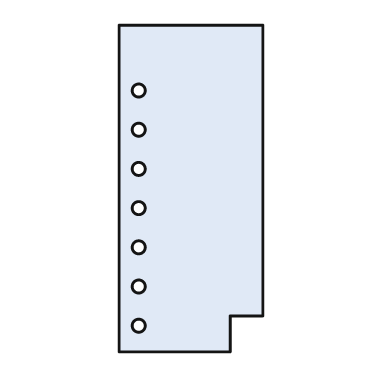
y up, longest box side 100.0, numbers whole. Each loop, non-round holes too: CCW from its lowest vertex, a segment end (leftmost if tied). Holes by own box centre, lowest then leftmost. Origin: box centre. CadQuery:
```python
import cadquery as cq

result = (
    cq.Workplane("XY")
    .moveTo(-22.0, -50.0)
    .lineTo(12.0, -50.0)
    .lineTo(12.0, -39.0)
    .lineTo(22.0, -39.0)
    .lineTo(22.0, 50.0)
    .lineTo(-22.0, 50.0)
    .close()
    .moveTo(-16.0, -42.0)
    .circle(2.0)
    .moveTo(-16.0, -30.0)
    .circle(2.0)
    .moveTo(-16.0, -18.0)
    .circle(2.0)
    .moveTo(-16.0, -6.0)
    .circle(2.0)
    .moveTo(-16.0, 6.0)
    .circle(2.0)
    .moveTo(-16.0, 18.0)
    .circle(2.0)
    .moveTo(-16.0, 30.0)
    .circle(2.0)
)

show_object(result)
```